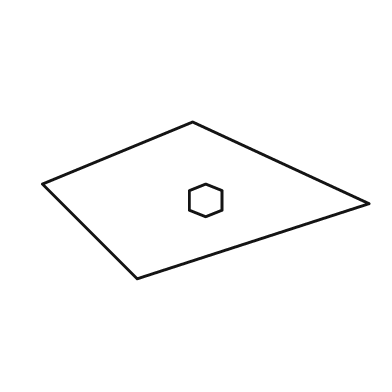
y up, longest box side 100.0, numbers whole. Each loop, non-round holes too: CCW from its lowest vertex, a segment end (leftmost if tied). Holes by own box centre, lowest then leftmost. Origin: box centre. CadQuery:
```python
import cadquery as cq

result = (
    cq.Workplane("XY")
    .moveTo(-21.0, -24.0)
    .lineTo(50.0, -1.0)
    .lineTo(-4.0, 24.0)
    .lineTo(-50.0, 5.0)
    .close()
    .moveTo(0.0, -5.0)
    .lineTo(5.0, -3.0)
    .lineTo(5.0, 3.0)
    .lineTo(0.0, 5.0)
    .lineTo(-5.0, 3.0)
    .lineTo(-5.0, -3.0)
    .close()
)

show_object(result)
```